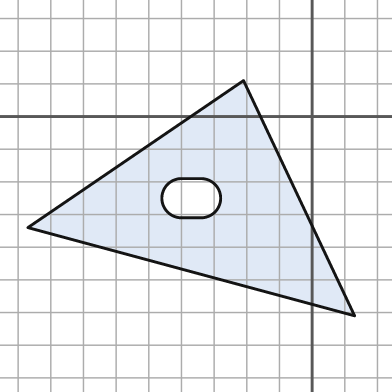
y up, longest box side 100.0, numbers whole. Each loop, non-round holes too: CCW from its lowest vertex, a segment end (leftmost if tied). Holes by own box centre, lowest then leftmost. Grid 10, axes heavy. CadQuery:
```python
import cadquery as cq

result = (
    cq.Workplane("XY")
    .moveTo(13.0, -61.0)
    .lineTo(-21.0, 11.0)
    .lineTo(-87.0, -34.0)
    .close()
    .moveTo(-40.0, -31.0)
    .lineTo(-34.0, -31.0)
    .threePointArc((-28.0, -25.0), (-34.0, -19.0))
    .lineTo(-40.0, -19.0)
    .threePointArc((-46.0, -25.0), (-40.0, -31.0))
    .close()
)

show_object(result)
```